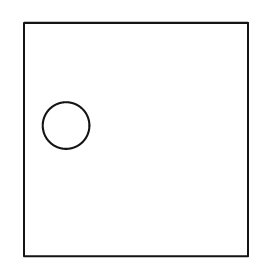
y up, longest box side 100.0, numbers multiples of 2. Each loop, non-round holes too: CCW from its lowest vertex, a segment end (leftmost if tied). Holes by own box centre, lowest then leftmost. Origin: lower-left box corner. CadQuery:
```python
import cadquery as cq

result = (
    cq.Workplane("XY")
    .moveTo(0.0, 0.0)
    .lineTo(96.0, 0.0)
    .lineTo(96.0, 100.0)
    .lineTo(0.0, 100.0)
    .close()
    .moveTo(18.0, 56.0)
    .circle(10.0)
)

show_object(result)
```